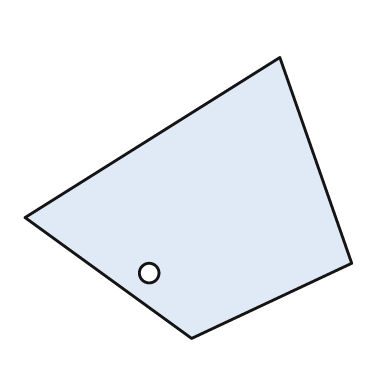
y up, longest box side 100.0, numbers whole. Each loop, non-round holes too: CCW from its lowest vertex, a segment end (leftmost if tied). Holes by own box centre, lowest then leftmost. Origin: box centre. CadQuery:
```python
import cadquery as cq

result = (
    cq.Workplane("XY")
    .moveTo(1.0, -43.0)
    .lineTo(50.0, -20.0)
    .lineTo(28.0, 43.0)
    .lineTo(-50.0, -6.0)
    .close()
    .moveTo(-12.0, -23.0)
    .circle(3.0)
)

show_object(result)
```